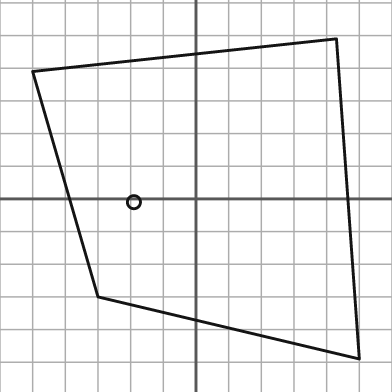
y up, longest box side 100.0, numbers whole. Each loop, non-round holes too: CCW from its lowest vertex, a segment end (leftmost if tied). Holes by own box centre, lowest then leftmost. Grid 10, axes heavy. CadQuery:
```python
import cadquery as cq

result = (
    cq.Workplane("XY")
    .moveTo(50.0, -49.0)
    .lineTo(43.0, 49.0)
    .lineTo(-50.0, 39.0)
    .lineTo(-30.0, -30.0)
    .close()
    .moveTo(-19.0, -1.0)
    .circle(2.0)
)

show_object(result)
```